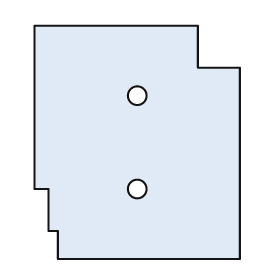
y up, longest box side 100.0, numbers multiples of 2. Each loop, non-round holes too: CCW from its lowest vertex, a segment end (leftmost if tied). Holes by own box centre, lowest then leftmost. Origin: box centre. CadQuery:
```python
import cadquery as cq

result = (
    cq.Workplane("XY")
    .moveTo(-34.0, -50.0)
    .lineTo(44.0, -50.0)
    .lineTo(44.0, 32.0)
    .lineTo(26.0, 32.0)
    .lineTo(26.0, 50.0)
    .lineTo(-44.0, 50.0)
    .lineTo(-44.0, -20.0)
    .lineTo(-38.0, -20.0)
    .lineTo(-38.0, -38.0)
    .lineTo(-34.0, -38.0)
    .close()
    .moveTo(0.0, -20.0)
    .circle(4.0)
    .moveTo(0.0, 20.0)
    .circle(4.0)
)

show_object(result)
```